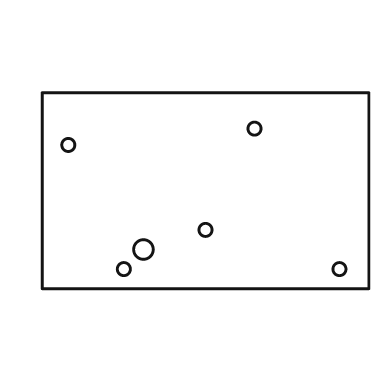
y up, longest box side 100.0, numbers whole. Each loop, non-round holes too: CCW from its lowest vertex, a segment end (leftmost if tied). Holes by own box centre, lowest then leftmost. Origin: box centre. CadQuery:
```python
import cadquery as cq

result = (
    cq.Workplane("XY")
    .moveTo(-50.0, -30.0)
    .lineTo(50.0, -30.0)
    .lineTo(50.0, 30.0)
    .lineTo(-50.0, 30.0)
    .close()
    .moveTo(-25.0, -24.0)
    .circle(2.0)
    .moveTo(41.0, -24.0)
    .circle(2.0)
    .moveTo(-19.0, -18.0)
    .circle(3.0)
    .moveTo(0.0, -12.0)
    .circle(2.0)
    .moveTo(-42.0, 14.0)
    .circle(2.0)
    .moveTo(15.0, 19.0)
    .circle(2.0)
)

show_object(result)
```